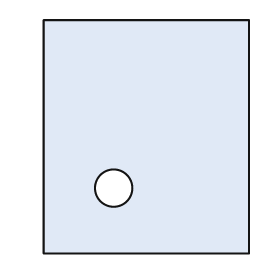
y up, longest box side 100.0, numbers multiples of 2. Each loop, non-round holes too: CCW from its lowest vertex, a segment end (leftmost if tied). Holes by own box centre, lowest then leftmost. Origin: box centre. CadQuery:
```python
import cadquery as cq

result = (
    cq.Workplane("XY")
    .moveTo(-44.0, -50.0)
    .lineTo(44.0, -50.0)
    .lineTo(44.0, 50.0)
    .lineTo(-44.0, 50.0)
    .close()
    .moveTo(-14.0, -22.0)
    .circle(8.0)
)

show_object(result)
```